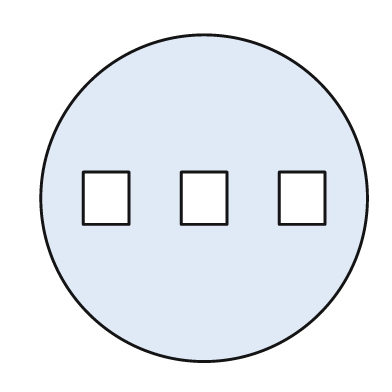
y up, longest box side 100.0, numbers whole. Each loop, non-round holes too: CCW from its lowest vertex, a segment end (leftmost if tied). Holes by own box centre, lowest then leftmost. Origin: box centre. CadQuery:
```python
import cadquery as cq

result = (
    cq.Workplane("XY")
    .moveTo(0.0, 0.0)
    .circle(50.0)
    .moveTo(-37.0, -8.0)
    .lineTo(-23.0, -8.0)
    .lineTo(-23.0, 8.0)
    .lineTo(-37.0, 8.0)
    .close()
    .moveTo(-7.0, -8.0)
    .lineTo(7.0, -8.0)
    .lineTo(7.0, 8.0)
    .lineTo(-7.0, 8.0)
    .close()
    .moveTo(23.0, -8.0)
    .lineTo(37.0, -8.0)
    .lineTo(37.0, 8.0)
    .lineTo(23.0, 8.0)
    .close()
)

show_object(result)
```